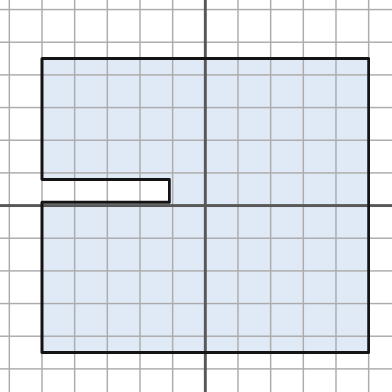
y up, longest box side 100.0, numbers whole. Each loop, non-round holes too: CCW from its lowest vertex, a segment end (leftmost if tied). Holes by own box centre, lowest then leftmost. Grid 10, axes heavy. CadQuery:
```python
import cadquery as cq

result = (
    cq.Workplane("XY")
    .moveTo(-50.0, -45.0)
    .lineTo(50.0, -45.0)
    .lineTo(50.0, 45.0)
    .lineTo(-50.0, 45.0)
    .lineTo(-50.0, 8.0)
    .lineTo(-11.0, 8.0)
    .lineTo(-11.0, 1.0)
    .lineTo(-50.0, 1.0)
    .close()
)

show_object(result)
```